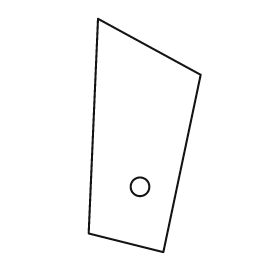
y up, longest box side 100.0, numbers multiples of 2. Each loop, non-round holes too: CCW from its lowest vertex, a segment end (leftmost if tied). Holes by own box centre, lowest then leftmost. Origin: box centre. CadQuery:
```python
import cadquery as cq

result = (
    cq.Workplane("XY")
    .moveTo(8.0, -50.0)
    .lineTo(24.0, 26.0)
    .lineTo(-20.0, 50.0)
    .lineTo(-24.0, -42.0)
    .close()
    .moveTo(-2.0, -22.0)
    .circle(4.0)
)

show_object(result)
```